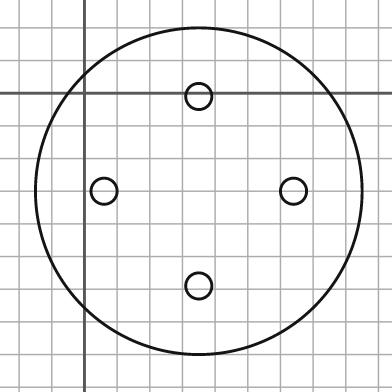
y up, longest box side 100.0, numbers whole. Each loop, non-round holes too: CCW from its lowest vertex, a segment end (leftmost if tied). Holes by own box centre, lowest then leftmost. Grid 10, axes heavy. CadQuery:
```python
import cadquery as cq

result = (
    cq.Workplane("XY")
    .moveTo(35.0, -30.0)
    .circle(50.0)
    .moveTo(35.0, -59.0)
    .circle(4.0)
    .moveTo(6.0, -30.0)
    .circle(4.0)
    .moveTo(64.0, -30.0)
    .circle(4.0)
    .moveTo(35.0, -1.0)
    .circle(4.0)
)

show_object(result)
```